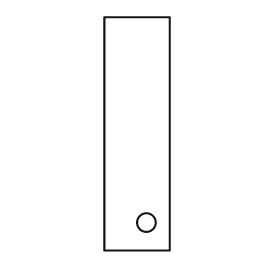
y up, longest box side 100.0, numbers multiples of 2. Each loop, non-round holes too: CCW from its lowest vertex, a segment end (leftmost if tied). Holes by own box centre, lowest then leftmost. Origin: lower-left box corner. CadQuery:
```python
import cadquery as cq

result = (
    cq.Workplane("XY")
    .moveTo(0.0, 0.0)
    .lineTo(28.0, 0.0)
    .lineTo(28.0, 100.0)
    .lineTo(0.0, 100.0)
    .close()
    .moveTo(18.0, 12.0)
    .circle(4.0)
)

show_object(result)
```